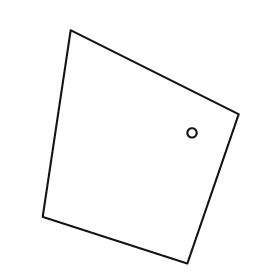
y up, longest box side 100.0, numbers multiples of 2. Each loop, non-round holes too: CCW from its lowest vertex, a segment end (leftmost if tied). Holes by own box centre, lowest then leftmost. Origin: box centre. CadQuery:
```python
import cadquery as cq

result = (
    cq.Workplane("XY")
    .moveTo(20.0, -50.0)
    .lineTo(42.0, 14.0)
    .lineTo(-30.0, 50.0)
    .lineTo(-42.0, -30.0)
    .close()
    .moveTo(22.0, 6.0)
    .circle(2.0)
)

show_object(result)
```